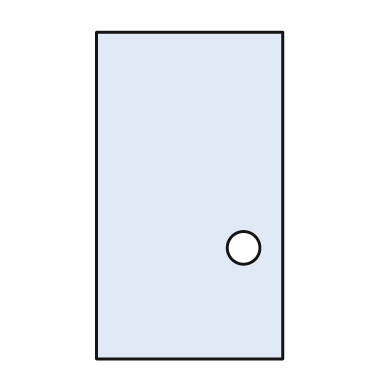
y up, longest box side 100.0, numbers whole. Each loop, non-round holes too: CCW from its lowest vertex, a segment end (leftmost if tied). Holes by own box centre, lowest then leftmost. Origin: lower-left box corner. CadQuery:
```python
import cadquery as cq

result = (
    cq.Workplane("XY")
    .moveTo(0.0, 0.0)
    .lineTo(57.0, 0.0)
    .lineTo(57.0, 100.0)
    .lineTo(0.0, 100.0)
    .close()
    .moveTo(45.0, 34.0)
    .circle(5.0)
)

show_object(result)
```